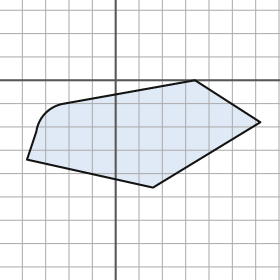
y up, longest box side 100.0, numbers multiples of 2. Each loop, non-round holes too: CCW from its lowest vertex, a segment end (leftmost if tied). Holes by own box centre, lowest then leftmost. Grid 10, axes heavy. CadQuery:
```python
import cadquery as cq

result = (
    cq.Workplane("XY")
    .moveTo(16.0, -46.0)
    .lineTo(62.0, -18.0)
    .lineTo(34.0, 0.0)
    .lineTo(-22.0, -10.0)
    .threePointArc((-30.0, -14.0), (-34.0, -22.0))
    .lineTo(-38.0, -34.0)
    .close()
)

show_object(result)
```